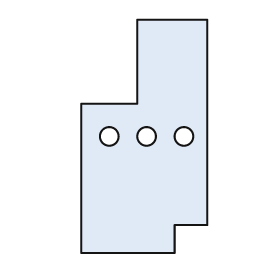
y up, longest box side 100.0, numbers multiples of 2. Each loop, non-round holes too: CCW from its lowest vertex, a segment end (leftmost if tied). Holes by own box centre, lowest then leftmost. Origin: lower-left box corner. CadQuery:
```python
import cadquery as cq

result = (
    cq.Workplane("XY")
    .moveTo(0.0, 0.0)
    .lineTo(40.0, 0.0)
    .lineTo(40.0, 12.0)
    .lineTo(54.0, 12.0)
    .lineTo(54.0, 100.0)
    .lineTo(24.0, 100.0)
    .lineTo(24.0, 64.0)
    .lineTo(0.0, 64.0)
    .close()
    .moveTo(12.0, 50.0)
    .circle(4.0)
    .moveTo(28.0, 50.0)
    .circle(4.0)
    .moveTo(44.0, 50.0)
    .circle(4.0)
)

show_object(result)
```